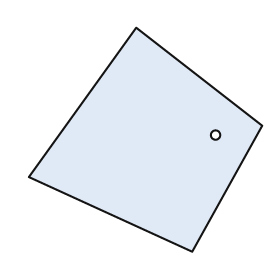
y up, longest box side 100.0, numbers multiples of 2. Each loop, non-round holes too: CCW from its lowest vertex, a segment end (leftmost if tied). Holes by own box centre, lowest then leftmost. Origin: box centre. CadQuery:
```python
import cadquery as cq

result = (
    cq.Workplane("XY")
    .moveTo(20.0, -48.0)
    .lineTo(50.0, 6.0)
    .lineTo(-4.0, 48.0)
    .lineTo(-50.0, -16.0)
    .close()
    .moveTo(30.0, 2.0)
    .circle(2.0)
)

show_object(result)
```